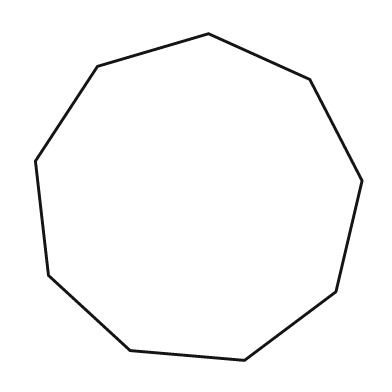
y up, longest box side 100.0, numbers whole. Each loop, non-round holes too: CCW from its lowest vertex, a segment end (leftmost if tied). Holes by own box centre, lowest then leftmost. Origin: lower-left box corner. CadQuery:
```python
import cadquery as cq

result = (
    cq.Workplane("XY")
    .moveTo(64.0, 0.0)
    .lineTo(92.0, 21.0)
    .lineTo(100.0, 55.0)
    .lineTo(84.0, 86.0)
    .lineTo(53.0, 100.0)
    .lineTo(19.0, 90.0)
    .lineTo(0.0, 61.0)
    .lineTo(4.0, 26.0)
    .lineTo(29.0, 3.0)
    .close()
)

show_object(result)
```